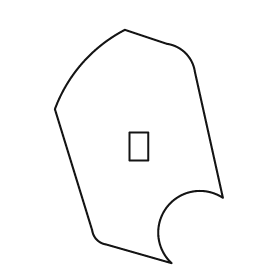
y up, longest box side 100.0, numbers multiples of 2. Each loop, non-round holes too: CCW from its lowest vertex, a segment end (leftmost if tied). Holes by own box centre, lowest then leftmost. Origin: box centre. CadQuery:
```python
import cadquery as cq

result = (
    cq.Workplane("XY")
    .moveTo(14.0, -50.0)
    .threePointArc((12.0, -26.0), (36.0, -22.0))
    .lineTo(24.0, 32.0)
    .threePointArc((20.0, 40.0), (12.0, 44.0))
    .lineTo(-6.0, 50.0)
    .threePointArc((-24.0, 36.0), (-36.0, 16.0))
    .lineTo(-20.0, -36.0)
    .threePointArc((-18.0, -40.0), (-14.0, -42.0))
    .close()
    .moveTo(-4.0, -6.0)
    .lineTo(4.0, -6.0)
    .lineTo(4.0, 6.0)
    .lineTo(-4.0, 6.0)
    .close()
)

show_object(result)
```